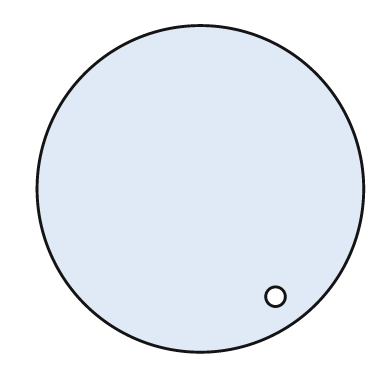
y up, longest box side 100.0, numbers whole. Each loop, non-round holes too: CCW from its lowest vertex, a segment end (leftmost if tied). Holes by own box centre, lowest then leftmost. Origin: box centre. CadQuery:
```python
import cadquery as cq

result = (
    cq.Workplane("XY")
    .moveTo(0.0, 0.0)
    .circle(50.0)
    .moveTo(23.0, -33.0)
    .circle(3.0)
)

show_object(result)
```